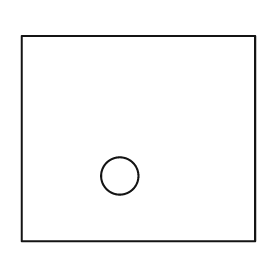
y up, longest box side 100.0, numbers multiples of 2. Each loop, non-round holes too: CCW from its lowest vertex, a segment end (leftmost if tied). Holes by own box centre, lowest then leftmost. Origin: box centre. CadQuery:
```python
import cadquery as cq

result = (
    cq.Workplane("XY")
    .moveTo(-50.0, -44.0)
    .lineTo(50.0, -44.0)
    .lineTo(50.0, 44.0)
    .lineTo(-50.0, 44.0)
    .close()
    .moveTo(-8.0, -16.0)
    .circle(8.0)
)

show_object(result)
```